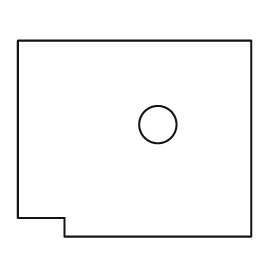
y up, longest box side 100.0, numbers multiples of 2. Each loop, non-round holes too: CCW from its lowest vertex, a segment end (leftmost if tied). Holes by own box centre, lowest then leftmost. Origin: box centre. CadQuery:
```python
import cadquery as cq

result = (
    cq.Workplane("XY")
    .moveTo(-30.0, -42.0)
    .lineTo(50.0, -42.0)
    .lineTo(50.0, 42.0)
    .lineTo(-50.0, 42.0)
    .lineTo(-50.0, -34.0)
    .lineTo(-30.0, -34.0)
    .close()
    .moveTo(10.0, 6.0)
    .circle(8.0)
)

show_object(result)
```